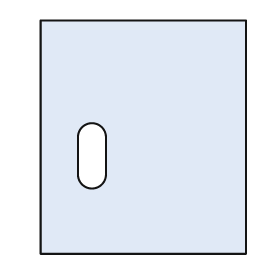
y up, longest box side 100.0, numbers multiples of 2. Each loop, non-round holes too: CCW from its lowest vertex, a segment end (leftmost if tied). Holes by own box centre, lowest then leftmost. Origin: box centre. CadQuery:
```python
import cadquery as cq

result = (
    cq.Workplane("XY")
    .moveTo(-44.0, -50.0)
    .lineTo(44.0, -50.0)
    .lineTo(44.0, 50.0)
    .lineTo(-44.0, 50.0)
    .close()
    .moveTo(-28.0, -16.0)
    .threePointArc((-22.0, -22.0), (-16.0, -16.0))
    .lineTo(-16.0, 0.0)
    .threePointArc((-22.0, 6.0), (-28.0, 0.0))
    .close()
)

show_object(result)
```